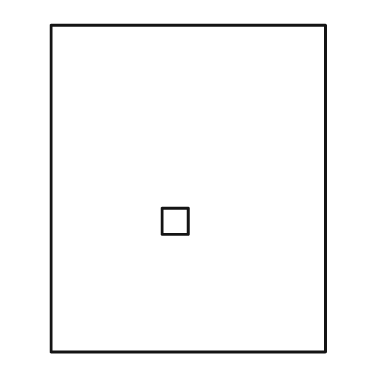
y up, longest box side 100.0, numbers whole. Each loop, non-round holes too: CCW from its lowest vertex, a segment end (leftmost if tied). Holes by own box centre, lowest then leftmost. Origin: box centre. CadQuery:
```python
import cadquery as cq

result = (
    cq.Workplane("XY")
    .moveTo(-42.0, -50.0)
    .lineTo(42.0, -50.0)
    .lineTo(42.0, 50.0)
    .lineTo(-42.0, 50.0)
    .close()
    .moveTo(-8.0, -14.0)
    .lineTo(0.0, -14.0)
    .lineTo(0.0, -6.0)
    .lineTo(-8.0, -6.0)
    .close()
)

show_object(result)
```